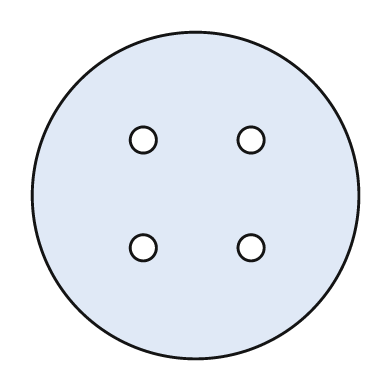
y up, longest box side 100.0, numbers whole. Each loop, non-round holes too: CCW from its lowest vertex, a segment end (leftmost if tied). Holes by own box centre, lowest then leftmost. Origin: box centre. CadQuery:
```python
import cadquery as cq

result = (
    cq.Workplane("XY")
    .moveTo(0.0, 0.0)
    .circle(50.0)
    .moveTo(-16.0, -16.0)
    .circle(4.0)
    .moveTo(17.0, -16.0)
    .circle(4.0)
    .moveTo(-16.0, 17.0)
    .circle(4.0)
    .moveTo(17.0, 17.0)
    .circle(4.0)
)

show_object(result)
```